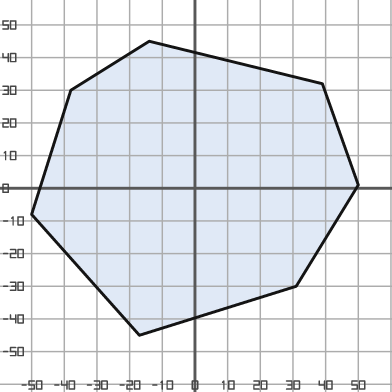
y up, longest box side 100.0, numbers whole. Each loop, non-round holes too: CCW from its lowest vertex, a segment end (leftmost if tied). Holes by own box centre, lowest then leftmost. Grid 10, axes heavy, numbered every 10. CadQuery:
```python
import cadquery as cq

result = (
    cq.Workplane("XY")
    .moveTo(-17.0, -45.0)
    .lineTo(31.0, -30.0)
    .lineTo(50.0, 1.0)
    .lineTo(39.0, 32.0)
    .lineTo(-14.0, 45.0)
    .lineTo(-38.0, 30.0)
    .lineTo(-50.0, -8.0)
    .close()
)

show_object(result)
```